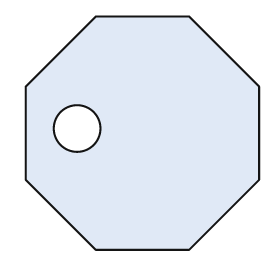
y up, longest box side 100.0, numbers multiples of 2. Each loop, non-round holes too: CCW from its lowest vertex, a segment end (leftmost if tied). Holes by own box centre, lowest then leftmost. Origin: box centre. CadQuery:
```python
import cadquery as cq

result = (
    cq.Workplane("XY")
    .moveTo(-20.0, -50.0)
    .lineTo(20.0, -50.0)
    .lineTo(50.0, -20.0)
    .lineTo(50.0, 20.0)
    .lineTo(20.0, 50.0)
    .lineTo(-20.0, 50.0)
    .lineTo(-50.0, 20.0)
    .lineTo(-50.0, -20.0)
    .close()
    .moveTo(-28.0, 2.0)
    .circle(10.0)
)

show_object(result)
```